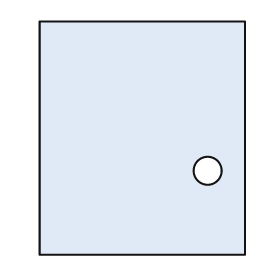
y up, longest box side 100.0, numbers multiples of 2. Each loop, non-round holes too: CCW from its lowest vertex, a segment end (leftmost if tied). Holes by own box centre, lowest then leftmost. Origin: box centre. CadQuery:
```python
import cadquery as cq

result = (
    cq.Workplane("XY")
    .moveTo(-44.0, -50.0)
    .lineTo(44.0, -50.0)
    .lineTo(44.0, 50.0)
    .lineTo(-44.0, 50.0)
    .close()
    .moveTo(28.0, -14.0)
    .circle(6.0)
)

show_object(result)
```